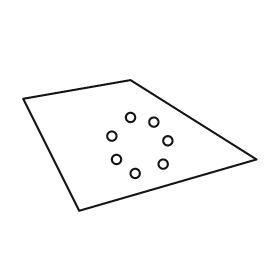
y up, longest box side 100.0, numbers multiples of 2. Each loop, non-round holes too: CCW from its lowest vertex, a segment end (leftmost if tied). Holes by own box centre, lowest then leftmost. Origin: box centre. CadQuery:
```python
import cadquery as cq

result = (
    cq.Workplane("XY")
    .moveTo(-26.0, -28.0)
    .lineTo(50.0, -6.0)
    .lineTo(-4.0, 28.0)
    .lineTo(-50.0, 20.0)
    .close()
    .moveTo(-2.0, -12.0)
    .circle(2.0)
    .moveTo(10.0, -8.0)
    .circle(2.0)
    .moveTo(-10.0, -6.0)
    .circle(2.0)
    .moveTo(12.0, 2.0)
    .circle(2.0)
    .moveTo(-12.0, 4.0)
    .circle(2.0)
    .moveTo(6.0, 10.0)
    .circle(2.0)
    .moveTo(-4.0, 12.0)
    .circle(2.0)
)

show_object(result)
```